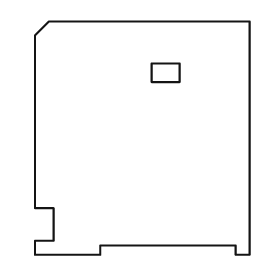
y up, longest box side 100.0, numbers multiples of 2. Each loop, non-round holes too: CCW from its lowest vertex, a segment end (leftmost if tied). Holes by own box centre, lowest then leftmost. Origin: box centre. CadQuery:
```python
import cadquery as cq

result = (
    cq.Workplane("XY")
    .moveTo(-46.0, -50.0)
    .lineTo(-18.0, -50.0)
    .lineTo(-18.0, -46.0)
    .lineTo(40.0, -46.0)
    .lineTo(40.0, -50.0)
    .lineTo(46.0, -50.0)
    .lineTo(46.0, 50.0)
    .lineTo(-40.0, 50.0)
    .lineTo(-46.0, 44.0)
    .lineTo(-46.0, -30.0)
    .lineTo(-38.0, -30.0)
    .lineTo(-38.0, -44.0)
    .lineTo(-46.0, -44.0)
    .close()
    .moveTo(4.0, 24.0)
    .lineTo(16.0, 24.0)
    .lineTo(16.0, 32.0)
    .lineTo(4.0, 32.0)
    .close()
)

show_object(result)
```